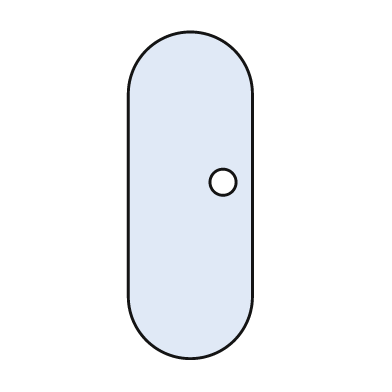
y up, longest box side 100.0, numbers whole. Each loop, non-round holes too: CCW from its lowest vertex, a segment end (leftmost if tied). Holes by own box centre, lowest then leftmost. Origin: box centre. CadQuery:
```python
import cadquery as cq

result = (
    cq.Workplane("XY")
    .moveTo(-19.0, -31.0)
    .threePointArc((0.0, -50.0), (19.0, -31.0))
    .lineTo(19.0, 31.0)
    .threePointArc((0.0, 50.0), (-19.0, 31.0))
    .close()
    .moveTo(10.0, 4.0)
    .circle(4.0)
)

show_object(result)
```